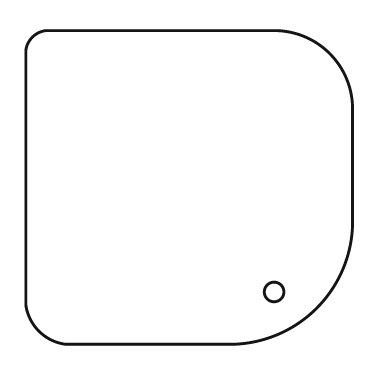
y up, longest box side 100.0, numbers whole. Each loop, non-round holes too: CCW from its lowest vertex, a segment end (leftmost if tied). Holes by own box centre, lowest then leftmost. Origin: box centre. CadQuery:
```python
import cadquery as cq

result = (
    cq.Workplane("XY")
    .moveTo(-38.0, -48.0)
    .lineTo(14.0, -48.0)
    .threePointArc((39.0, -37.0), (50.0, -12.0))
    .lineTo(50.0, 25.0)
    .threePointArc((43.0, 41.0), (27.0, 48.0))
    .lineTo(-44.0, 48.0)
    .threePointArc((-48.0, 46.0), (-50.0, 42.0))
    .lineTo(-50.0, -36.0)
    .threePointArc((-46.0, -44.0), (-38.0, -48.0))
    .close()
    .moveTo(26.0, -32.0)
    .circle(3.0)
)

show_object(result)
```